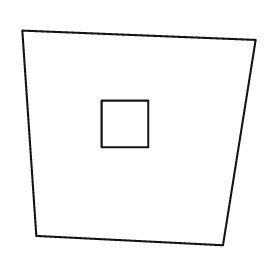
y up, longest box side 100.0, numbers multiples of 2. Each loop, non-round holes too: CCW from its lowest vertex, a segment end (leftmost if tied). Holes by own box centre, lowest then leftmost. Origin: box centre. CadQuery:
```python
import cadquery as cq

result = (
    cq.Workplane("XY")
    .moveTo(36.0, -46.0)
    .lineTo(50.0, 42.0)
    .lineTo(-50.0, 46.0)
    .lineTo(-44.0, -42.0)
    .close()
    .moveTo(-16.0, -4.0)
    .lineTo(4.0, -4.0)
    .lineTo(4.0, 16.0)
    .lineTo(-16.0, 16.0)
    .close()
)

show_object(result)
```